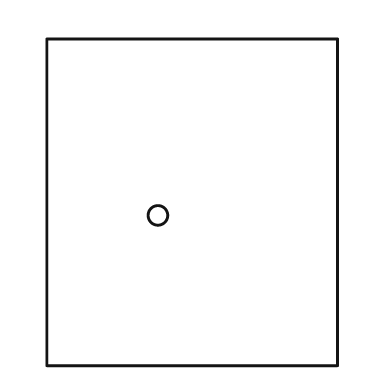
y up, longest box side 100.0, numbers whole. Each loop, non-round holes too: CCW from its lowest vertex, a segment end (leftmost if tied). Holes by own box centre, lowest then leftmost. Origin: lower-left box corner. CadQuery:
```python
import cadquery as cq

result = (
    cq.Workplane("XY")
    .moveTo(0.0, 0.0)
    .lineTo(89.0, 0.0)
    .lineTo(89.0, 100.0)
    .lineTo(0.0, 100.0)
    .close()
    .moveTo(34.0, 46.0)
    .circle(3.0)
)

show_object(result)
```